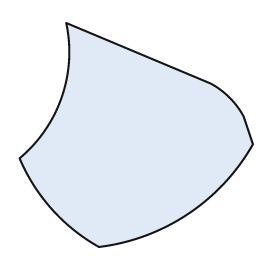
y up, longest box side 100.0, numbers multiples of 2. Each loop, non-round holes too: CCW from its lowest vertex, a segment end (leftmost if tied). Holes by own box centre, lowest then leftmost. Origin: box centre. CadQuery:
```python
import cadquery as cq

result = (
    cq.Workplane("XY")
    .moveTo(-16.0, -48.0)
    .threePointArc((22.0, -34.0), (50.0, -4.0))
    .lineTo(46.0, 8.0)
    .threePointArc((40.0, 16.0), (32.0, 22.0))
    .lineTo(-30.0, 48.0)
    .threePointArc((-32.0, 16.0), (-50.0, -10.0))
    .threePointArc((-36.0, -32.0), (-16.0, -48.0))
    .close()
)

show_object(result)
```